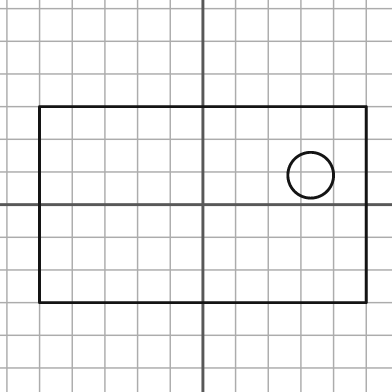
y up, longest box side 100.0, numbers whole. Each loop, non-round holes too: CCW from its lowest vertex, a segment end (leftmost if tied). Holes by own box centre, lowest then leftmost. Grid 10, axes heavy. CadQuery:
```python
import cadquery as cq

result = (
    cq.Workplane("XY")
    .moveTo(-50.0, -30.0)
    .lineTo(50.0, -30.0)
    .lineTo(50.0, 30.0)
    .lineTo(-50.0, 30.0)
    .close()
    .moveTo(33.0, 9.0)
    .circle(7.0)
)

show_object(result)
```